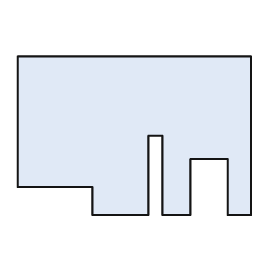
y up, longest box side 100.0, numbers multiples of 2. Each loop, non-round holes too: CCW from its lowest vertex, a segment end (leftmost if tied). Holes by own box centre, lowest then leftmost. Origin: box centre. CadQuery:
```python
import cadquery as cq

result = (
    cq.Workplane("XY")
    .moveTo(-18.0, -34.0)
    .lineTo(6.0, -34.0)
    .lineTo(6.0, 0.0)
    .lineTo(12.0, 0.0)
    .lineTo(12.0, -34.0)
    .lineTo(24.0, -34.0)
    .lineTo(24.0, -10.0)
    .lineTo(40.0, -10.0)
    .lineTo(40.0, -34.0)
    .lineTo(50.0, -34.0)
    .lineTo(50.0, 34.0)
    .lineTo(-50.0, 34.0)
    .lineTo(-50.0, -22.0)
    .lineTo(-18.0, -22.0)
    .close()
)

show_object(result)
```